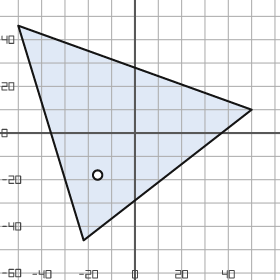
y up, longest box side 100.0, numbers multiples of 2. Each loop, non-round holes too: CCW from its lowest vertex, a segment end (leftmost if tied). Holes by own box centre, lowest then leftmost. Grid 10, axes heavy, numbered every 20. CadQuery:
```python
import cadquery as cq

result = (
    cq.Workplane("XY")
    .moveTo(-22.0, -46.0)
    .lineTo(50.0, 10.0)
    .lineTo(-50.0, 46.0)
    .close()
    .moveTo(-16.0, -18.0)
    .circle(2.0)
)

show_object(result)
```